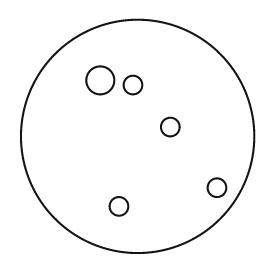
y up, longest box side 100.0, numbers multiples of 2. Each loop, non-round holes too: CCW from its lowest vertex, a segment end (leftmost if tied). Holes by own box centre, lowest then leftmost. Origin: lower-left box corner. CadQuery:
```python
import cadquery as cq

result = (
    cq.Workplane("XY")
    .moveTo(50.0, 50.0)
    .circle(50.0)
    .moveTo(42.0, 20.0)
    .circle(4.0)
    .moveTo(84.0, 28.0)
    .circle(4.0)
    .moveTo(64.0, 54.0)
    .circle(4.0)
    .moveTo(48.0, 72.0)
    .circle(4.0)
    .moveTo(34.0, 74.0)
    .circle(6.0)
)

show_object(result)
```